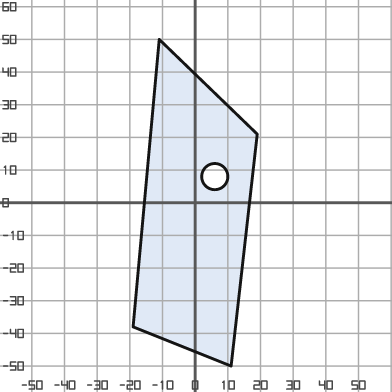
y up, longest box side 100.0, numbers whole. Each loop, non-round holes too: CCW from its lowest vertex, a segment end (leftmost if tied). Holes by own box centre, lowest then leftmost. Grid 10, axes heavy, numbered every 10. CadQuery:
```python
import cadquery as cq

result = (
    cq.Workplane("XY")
    .moveTo(11.0, -50.0)
    .lineTo(19.0, 21.0)
    .lineTo(-11.0, 50.0)
    .lineTo(-19.0, -38.0)
    .close()
    .moveTo(6.0, 8.0)
    .circle(4.0)
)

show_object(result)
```